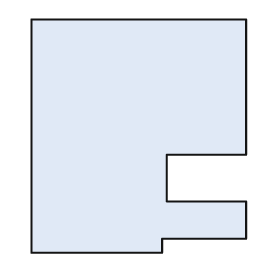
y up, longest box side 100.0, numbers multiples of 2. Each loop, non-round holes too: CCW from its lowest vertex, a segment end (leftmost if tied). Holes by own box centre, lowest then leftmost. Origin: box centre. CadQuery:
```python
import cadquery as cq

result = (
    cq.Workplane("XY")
    .moveTo(-46.0, -50.0)
    .lineTo(10.0, -50.0)
    .lineTo(10.0, -44.0)
    .lineTo(46.0, -44.0)
    .lineTo(46.0, -28.0)
    .lineTo(12.0, -28.0)
    .lineTo(12.0, -8.0)
    .lineTo(46.0, -8.0)
    .lineTo(46.0, 50.0)
    .lineTo(-46.0, 50.0)
    .close()
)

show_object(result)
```